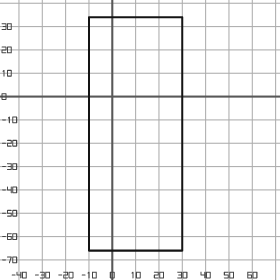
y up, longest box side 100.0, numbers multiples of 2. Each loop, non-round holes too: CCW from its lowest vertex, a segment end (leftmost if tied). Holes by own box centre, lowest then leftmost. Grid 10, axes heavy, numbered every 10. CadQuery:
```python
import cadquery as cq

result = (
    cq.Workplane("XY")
    .moveTo(-10.0, -66.0)
    .lineTo(30.0, -66.0)
    .lineTo(30.0, 34.0)
    .lineTo(-10.0, 34.0)
    .close()
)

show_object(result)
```